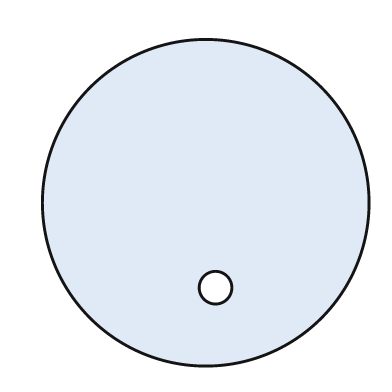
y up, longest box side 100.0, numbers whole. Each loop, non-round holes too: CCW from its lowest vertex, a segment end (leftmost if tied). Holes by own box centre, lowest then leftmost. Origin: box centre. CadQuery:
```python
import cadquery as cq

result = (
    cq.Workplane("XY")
    .moveTo(0.0, 0.0)
    .circle(50.0)
    .moveTo(3.0, -26.0)
    .circle(5.0)
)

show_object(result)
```